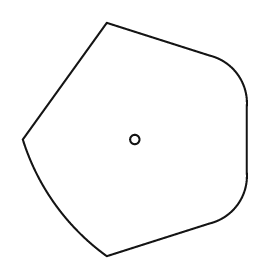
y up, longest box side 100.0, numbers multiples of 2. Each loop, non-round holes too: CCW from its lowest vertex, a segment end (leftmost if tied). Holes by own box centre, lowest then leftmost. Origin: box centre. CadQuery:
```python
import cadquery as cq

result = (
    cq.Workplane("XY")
    .moveTo(-12.0, -50.0)
    .lineTo(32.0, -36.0)
    .threePointArc((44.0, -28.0), (48.0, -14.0))
    .lineTo(48.0, 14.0)
    .threePointArc((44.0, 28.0), (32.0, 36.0))
    .lineTo(-12.0, 50.0)
    .lineTo(-48.0, 0.0)
    .threePointArc((-34.0, -28.0), (-12.0, -50.0))
    .close()
    .moveTo(0.0, 0.0)
    .circle(2.0)
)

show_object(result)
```